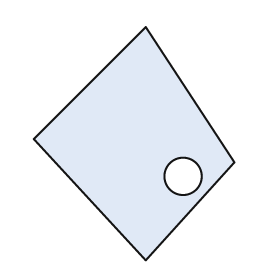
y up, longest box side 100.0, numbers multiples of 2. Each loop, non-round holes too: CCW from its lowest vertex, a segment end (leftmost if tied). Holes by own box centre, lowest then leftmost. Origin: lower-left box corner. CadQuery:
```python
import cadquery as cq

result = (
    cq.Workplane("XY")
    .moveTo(48.0, 0.0)
    .lineTo(86.0, 42.0)
    .lineTo(48.0, 100.0)
    .lineTo(0.0, 52.0)
    .close()
    .moveTo(64.0, 36.0)
    .circle(8.0)
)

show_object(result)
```